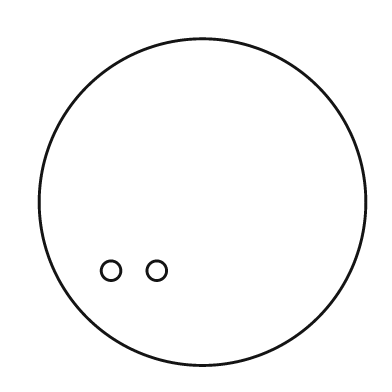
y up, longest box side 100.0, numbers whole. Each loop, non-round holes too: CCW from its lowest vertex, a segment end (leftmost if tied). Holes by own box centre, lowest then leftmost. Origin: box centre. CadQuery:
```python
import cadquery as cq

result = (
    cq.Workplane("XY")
    .moveTo(0.0, 0.0)
    .circle(50.0)
    .moveTo(-28.0, -21.0)
    .circle(3.0)
    .moveTo(-14.0, -21.0)
    .circle(3.0)
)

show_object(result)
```